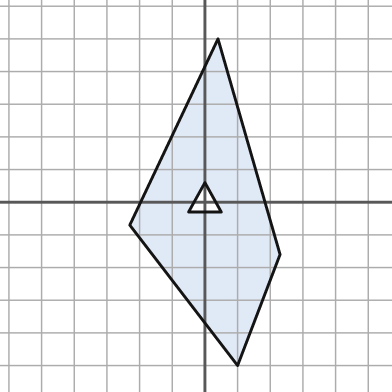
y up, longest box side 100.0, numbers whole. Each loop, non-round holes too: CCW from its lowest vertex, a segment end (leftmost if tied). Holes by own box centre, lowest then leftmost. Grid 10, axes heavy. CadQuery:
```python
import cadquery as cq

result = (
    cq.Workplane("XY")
    .moveTo(10.0, -50.0)
    .lineTo(23.0, -16.0)
    .lineTo(4.0, 50.0)
    .lineTo(-23.0, -7.0)
    .close()
    .moveTo(-5.0, -3.0)
    .lineTo(5.0, -3.0)
    .lineTo(0.0, 6.0)
    .close()
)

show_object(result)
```